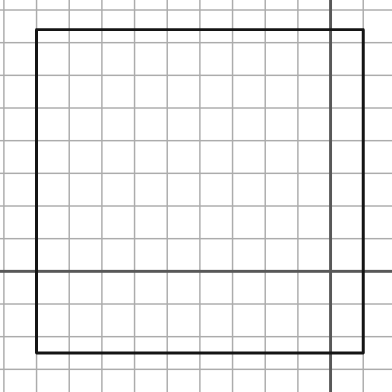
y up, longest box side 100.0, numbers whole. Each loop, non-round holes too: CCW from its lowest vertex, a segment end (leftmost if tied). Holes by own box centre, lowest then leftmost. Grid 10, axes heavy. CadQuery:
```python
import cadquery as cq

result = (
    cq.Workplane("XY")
    .moveTo(-90.0, -25.0)
    .lineTo(10.0, -25.0)
    .lineTo(10.0, 74.0)
    .lineTo(-90.0, 74.0)
    .close()
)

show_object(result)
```